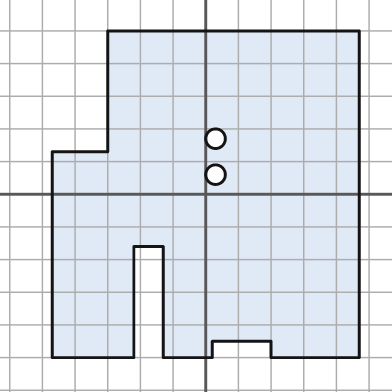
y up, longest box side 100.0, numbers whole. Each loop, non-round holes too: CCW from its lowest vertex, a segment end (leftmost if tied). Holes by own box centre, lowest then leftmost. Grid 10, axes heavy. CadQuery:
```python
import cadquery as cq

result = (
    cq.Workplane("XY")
    .moveTo(-47.0, -50.0)
    .lineTo(-22.0, -50.0)
    .lineTo(-22.0, -16.0)
    .lineTo(-13.0, -16.0)
    .lineTo(-13.0, -50.0)
    .lineTo(2.0, -50.0)
    .lineTo(2.0, -45.0)
    .lineTo(20.0, -45.0)
    .lineTo(20.0, -50.0)
    .lineTo(47.0, -50.0)
    .lineTo(47.0, 50.0)
    .lineTo(-30.0, 50.0)
    .lineTo(-30.0, 13.0)
    .lineTo(-47.0, 13.0)
    .close()
    .moveTo(3.0, 6.0)
    .circle(3.0)
    .moveTo(3.0, 17.0)
    .circle(3.0)
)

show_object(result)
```